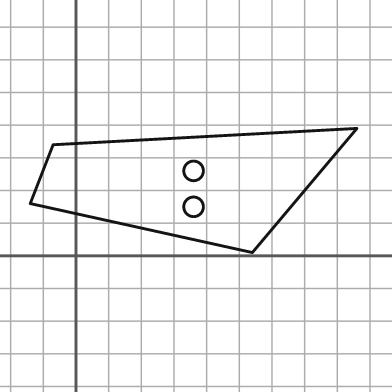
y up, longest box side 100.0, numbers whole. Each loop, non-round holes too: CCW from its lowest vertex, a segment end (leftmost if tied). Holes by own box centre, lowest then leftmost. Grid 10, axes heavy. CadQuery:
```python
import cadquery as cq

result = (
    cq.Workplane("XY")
    .moveTo(54.0, 1.0)
    .lineTo(86.0, 39.0)
    .lineTo(-7.0, 34.0)
    .lineTo(-14.0, 16.0)
    .close()
    .moveTo(36.0, 15.0)
    .circle(3.0)
    .moveTo(36.0, 26.0)
    .circle(3.0)
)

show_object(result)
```